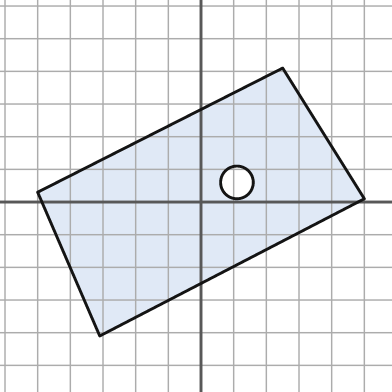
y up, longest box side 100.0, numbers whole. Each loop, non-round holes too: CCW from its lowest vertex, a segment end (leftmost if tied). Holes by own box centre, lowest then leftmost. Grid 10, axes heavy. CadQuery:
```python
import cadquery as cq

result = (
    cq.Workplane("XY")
    .moveTo(-31.0, -41.0)
    .lineTo(50.0, 1.0)
    .lineTo(25.0, 41.0)
    .lineTo(-50.0, 3.0)
    .close()
    .moveTo(11.0, 6.0)
    .circle(5.0)
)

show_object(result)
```